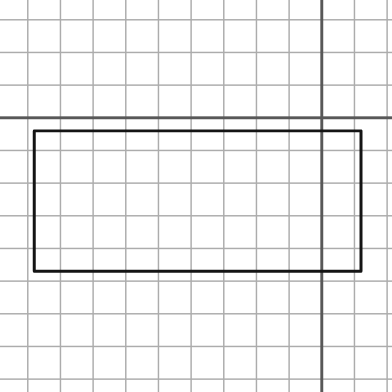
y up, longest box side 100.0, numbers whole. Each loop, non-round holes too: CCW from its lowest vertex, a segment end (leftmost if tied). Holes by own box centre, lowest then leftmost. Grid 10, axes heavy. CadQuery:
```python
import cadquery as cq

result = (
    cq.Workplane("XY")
    .moveTo(-88.0, -47.0)
    .lineTo(12.0, -47.0)
    .lineTo(12.0, -4.0)
    .lineTo(-88.0, -4.0)
    .close()
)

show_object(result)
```